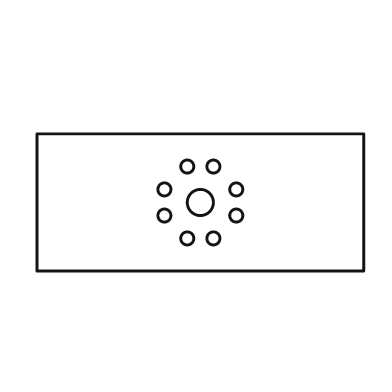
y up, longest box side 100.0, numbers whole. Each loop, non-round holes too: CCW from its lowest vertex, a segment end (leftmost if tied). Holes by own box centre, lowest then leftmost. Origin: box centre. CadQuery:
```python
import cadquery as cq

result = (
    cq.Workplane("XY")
    .moveTo(-50.0, -21.0)
    .lineTo(50.0, -21.0)
    .lineTo(50.0, 21.0)
    .lineTo(-50.0, 21.0)
    .close()
    .moveTo(-4.0, -11.0)
    .circle(2.0)
    .moveTo(4.0, -11.0)
    .circle(2.0)
    .moveTo(-11.0, -4.0)
    .circle(2.0)
    .moveTo(11.0, -4.0)
    .circle(2.0)
    .moveTo(0.0, 0.0)
    .circle(4.0)
    .moveTo(-11.0, 4.0)
    .circle(2.0)
    .moveTo(11.0, 4.0)
    .circle(2.0)
    .moveTo(-4.0, 11.0)
    .circle(2.0)
    .moveTo(4.0, 11.0)
    .circle(2.0)
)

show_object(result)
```